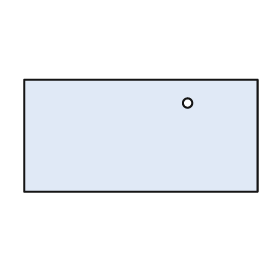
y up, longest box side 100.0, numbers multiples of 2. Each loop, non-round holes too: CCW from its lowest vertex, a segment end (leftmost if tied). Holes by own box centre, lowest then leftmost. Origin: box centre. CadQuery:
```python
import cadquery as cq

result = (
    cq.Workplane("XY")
    .moveTo(-50.0, -24.0)
    .lineTo(50.0, -24.0)
    .lineTo(50.0, 24.0)
    .lineTo(-50.0, 24.0)
    .close()
    .moveTo(20.0, 14.0)
    .circle(2.0)
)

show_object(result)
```